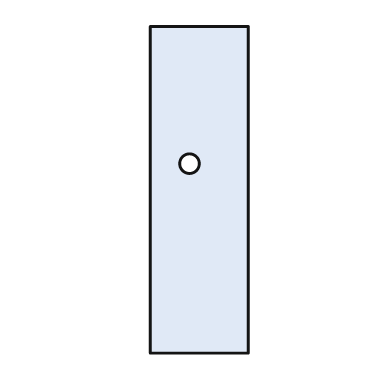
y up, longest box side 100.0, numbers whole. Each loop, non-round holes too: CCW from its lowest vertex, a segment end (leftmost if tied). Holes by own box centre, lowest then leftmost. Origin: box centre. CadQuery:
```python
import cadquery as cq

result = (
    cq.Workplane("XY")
    .moveTo(-15.0, -50.0)
    .lineTo(15.0, -50.0)
    .lineTo(15.0, 50.0)
    .lineTo(-15.0, 50.0)
    .close()
    .moveTo(-3.0, 8.0)
    .circle(3.0)
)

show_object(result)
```